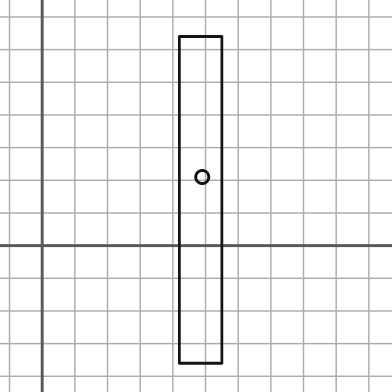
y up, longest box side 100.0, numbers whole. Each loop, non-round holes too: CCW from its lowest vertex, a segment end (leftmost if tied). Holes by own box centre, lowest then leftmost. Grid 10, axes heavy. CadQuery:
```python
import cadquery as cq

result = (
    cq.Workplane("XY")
    .moveTo(42.0, -36.0)
    .lineTo(55.0, -36.0)
    .lineTo(55.0, 64.0)
    .lineTo(42.0, 64.0)
    .close()
    .moveTo(49.0, 21.0)
    .circle(2.0)
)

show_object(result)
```